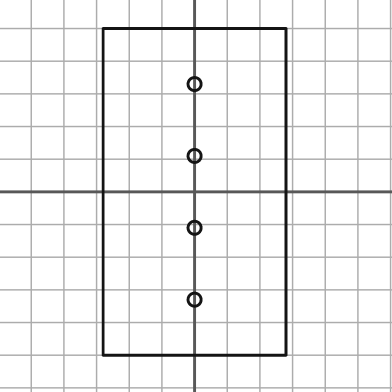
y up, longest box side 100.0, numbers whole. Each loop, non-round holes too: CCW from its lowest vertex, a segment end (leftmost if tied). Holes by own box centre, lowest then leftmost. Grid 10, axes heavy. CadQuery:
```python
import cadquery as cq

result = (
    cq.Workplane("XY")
    .moveTo(-28.0, -50.0)
    .lineTo(28.0, -50.0)
    .lineTo(28.0, 50.0)
    .lineTo(-28.0, 50.0)
    .close()
    .moveTo(0.0, -33.0)
    .circle(2.0)
    .moveTo(0.0, -11.0)
    .circle(2.0)
    .moveTo(0.0, 11.0)
    .circle(2.0)
    .moveTo(0.0, 33.0)
    .circle(2.0)
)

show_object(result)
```